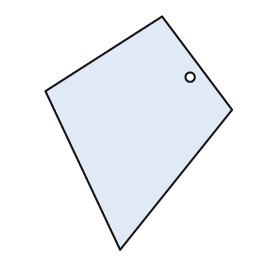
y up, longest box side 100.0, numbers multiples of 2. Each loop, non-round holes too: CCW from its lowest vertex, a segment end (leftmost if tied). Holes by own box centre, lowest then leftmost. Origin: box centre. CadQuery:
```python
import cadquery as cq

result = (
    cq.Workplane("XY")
    .moveTo(-8.0, -50.0)
    .lineTo(40.0, 10.0)
    .lineTo(10.0, 50.0)
    .lineTo(-40.0, 18.0)
    .close()
    .moveTo(22.0, 24.0)
    .circle(2.0)
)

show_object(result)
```